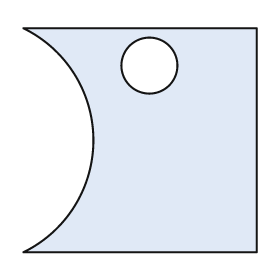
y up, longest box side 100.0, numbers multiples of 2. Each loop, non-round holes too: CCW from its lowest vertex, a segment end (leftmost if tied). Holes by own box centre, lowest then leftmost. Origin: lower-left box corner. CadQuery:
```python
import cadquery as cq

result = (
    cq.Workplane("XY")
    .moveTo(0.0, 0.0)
    .lineTo(100.0, 0.0)
    .lineTo(100.0, 96.0)
    .lineTo(0.0, 96.0)
    .threePointArc((30.0, 48.0), (0.0, 0.0))
    .close()
    .moveTo(54.0, 80.0)
    .circle(12.0)
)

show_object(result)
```